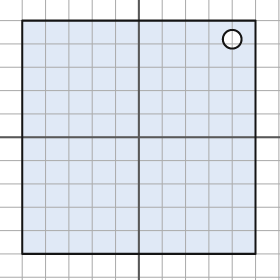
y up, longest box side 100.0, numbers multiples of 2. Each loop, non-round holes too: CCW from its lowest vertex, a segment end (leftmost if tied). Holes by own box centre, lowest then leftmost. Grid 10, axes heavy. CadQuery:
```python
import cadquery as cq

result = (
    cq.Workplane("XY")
    .moveTo(-50.0, -50.0)
    .lineTo(50.0, -50.0)
    .lineTo(50.0, 50.0)
    .lineTo(-50.0, 50.0)
    .close()
    .moveTo(40.0, 42.0)
    .circle(4.0)
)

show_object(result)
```